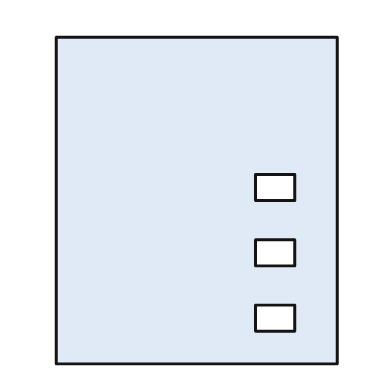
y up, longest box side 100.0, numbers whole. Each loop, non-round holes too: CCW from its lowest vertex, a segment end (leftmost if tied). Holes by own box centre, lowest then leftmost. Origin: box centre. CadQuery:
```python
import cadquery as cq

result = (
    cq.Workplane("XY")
    .moveTo(-43.0, -50.0)
    .lineTo(43.0, -50.0)
    .lineTo(43.0, 50.0)
    .lineTo(-43.0, 50.0)
    .close()
    .moveTo(18.0, -40.0)
    .lineTo(30.0, -40.0)
    .lineTo(30.0, -32.0)
    .lineTo(18.0, -32.0)
    .close()
    .moveTo(18.0, -20.0)
    .lineTo(30.0, -20.0)
    .lineTo(30.0, -12.0)
    .lineTo(18.0, -12.0)
    .close()
    .moveTo(18.0, 0.0)
    .lineTo(30.0, 0.0)
    .lineTo(30.0, 8.0)
    .lineTo(18.0, 8.0)
    .close()
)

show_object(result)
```